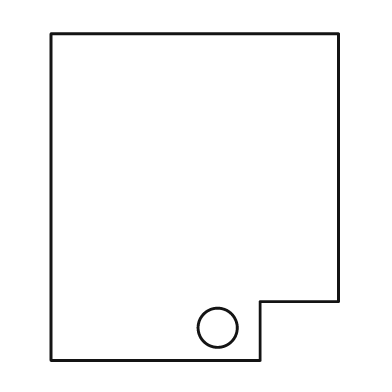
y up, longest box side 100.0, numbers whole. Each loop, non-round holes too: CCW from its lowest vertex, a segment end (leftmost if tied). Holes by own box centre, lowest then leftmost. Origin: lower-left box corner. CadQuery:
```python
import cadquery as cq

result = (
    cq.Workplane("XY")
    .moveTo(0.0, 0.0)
    .lineTo(64.0, 0.0)
    .lineTo(64.0, 18.0)
    .lineTo(88.0, 18.0)
    .lineTo(88.0, 100.0)
    .lineTo(0.0, 100.0)
    .close()
    .moveTo(51.0, 10.0)
    .circle(6.0)
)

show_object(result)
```